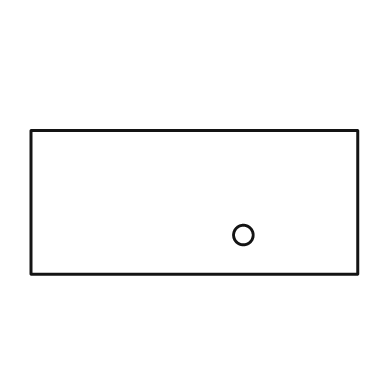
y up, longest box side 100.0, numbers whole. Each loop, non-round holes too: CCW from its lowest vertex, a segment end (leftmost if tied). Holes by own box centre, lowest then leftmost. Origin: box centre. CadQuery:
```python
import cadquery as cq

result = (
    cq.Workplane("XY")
    .moveTo(-50.0, -22.0)
    .lineTo(50.0, -22.0)
    .lineTo(50.0, 22.0)
    .lineTo(-50.0, 22.0)
    .close()
    .moveTo(15.0, -10.0)
    .circle(3.0)
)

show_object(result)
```